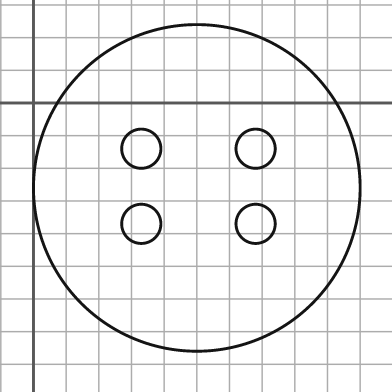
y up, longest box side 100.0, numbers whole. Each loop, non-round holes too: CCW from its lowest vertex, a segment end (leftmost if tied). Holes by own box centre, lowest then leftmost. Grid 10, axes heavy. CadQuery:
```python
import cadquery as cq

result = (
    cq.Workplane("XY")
    .moveTo(50.0, -26.0)
    .circle(50.0)
    .moveTo(33.0, -37.0)
    .circle(6.0)
    .moveTo(68.0, -37.0)
    .circle(6.0)
    .moveTo(33.0, -14.0)
    .circle(6.0)
    .moveTo(68.0, -14.0)
    .circle(6.0)
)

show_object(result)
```